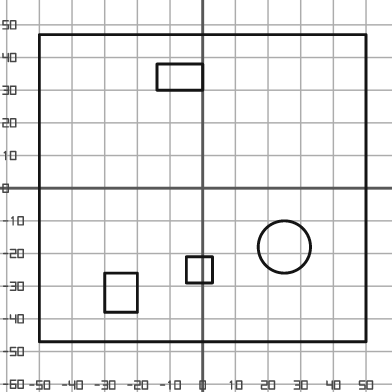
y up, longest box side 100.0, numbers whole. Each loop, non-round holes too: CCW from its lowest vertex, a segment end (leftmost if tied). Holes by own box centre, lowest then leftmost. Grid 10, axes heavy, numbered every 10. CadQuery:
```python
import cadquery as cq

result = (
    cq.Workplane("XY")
    .moveTo(-50.0, -47.0)
    .lineTo(50.0, -47.0)
    .lineTo(50.0, 47.0)
    .lineTo(-50.0, 47.0)
    .close()
    .moveTo(-30.0, -38.0)
    .lineTo(-20.0, -38.0)
    .lineTo(-20.0, -26.0)
    .lineTo(-30.0, -26.0)
    .close()
    .moveTo(-5.0, -29.0)
    .lineTo(3.0, -29.0)
    .lineTo(3.0, -21.0)
    .lineTo(-5.0, -21.0)
    .close()
    .moveTo(25.0, -18.0)
    .circle(8.0)
    .moveTo(-14.0, 30.0)
    .lineTo(0.0, 30.0)
    .lineTo(0.0, 38.0)
    .lineTo(-14.0, 38.0)
    .close()
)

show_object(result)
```